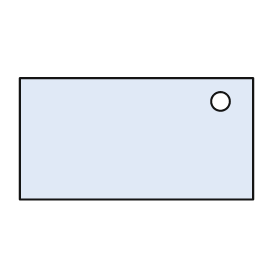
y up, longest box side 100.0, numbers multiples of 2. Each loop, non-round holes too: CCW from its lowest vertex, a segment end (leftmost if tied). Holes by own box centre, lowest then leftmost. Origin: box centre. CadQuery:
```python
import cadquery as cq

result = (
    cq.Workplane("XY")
    .moveTo(-50.0, -26.0)
    .lineTo(50.0, -26.0)
    .lineTo(50.0, 26.0)
    .lineTo(-50.0, 26.0)
    .close()
    .moveTo(36.0, 16.0)
    .circle(4.0)
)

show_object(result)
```